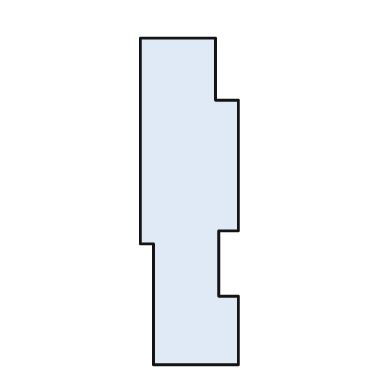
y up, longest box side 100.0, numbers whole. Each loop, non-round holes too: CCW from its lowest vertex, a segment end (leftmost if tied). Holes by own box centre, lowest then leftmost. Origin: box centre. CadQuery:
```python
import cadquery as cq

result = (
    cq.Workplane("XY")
    .moveTo(-11.0, -50.0)
    .lineTo(15.0, -50.0)
    .lineTo(15.0, -29.0)
    .lineTo(9.0, -29.0)
    .lineTo(9.0, -9.0)
    .lineTo(15.0, -9.0)
    .lineTo(15.0, 31.0)
    .lineTo(8.0, 31.0)
    .lineTo(8.0, 50.0)
    .lineTo(-15.0, 50.0)
    .lineTo(-15.0, -13.0)
    .lineTo(-11.0, -13.0)
    .close()
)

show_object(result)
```